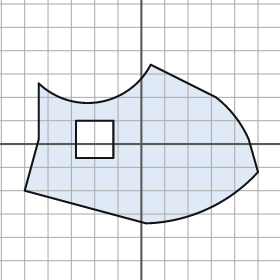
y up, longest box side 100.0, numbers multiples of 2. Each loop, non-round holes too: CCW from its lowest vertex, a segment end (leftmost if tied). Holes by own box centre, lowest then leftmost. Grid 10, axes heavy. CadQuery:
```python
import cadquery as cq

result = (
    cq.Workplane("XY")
    .moveTo(2.0, -34.0)
    .threePointArc((28.0, -28.0), (50.0, -12.0))
    .lineTo(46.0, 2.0)
    .threePointArc((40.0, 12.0), (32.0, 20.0))
    .lineTo(4.0, 34.0)
    .threePointArc((-18.0, 18.0), (-44.0, 26.0))
    .lineTo(-44.0, 2.0)
    .lineTo(-50.0, -20.0)
    .close()
    .moveTo(-28.0, -6.0)
    .lineTo(-12.0, -6.0)
    .lineTo(-12.0, 10.0)
    .lineTo(-28.0, 10.0)
    .close()
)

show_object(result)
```